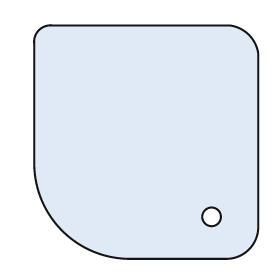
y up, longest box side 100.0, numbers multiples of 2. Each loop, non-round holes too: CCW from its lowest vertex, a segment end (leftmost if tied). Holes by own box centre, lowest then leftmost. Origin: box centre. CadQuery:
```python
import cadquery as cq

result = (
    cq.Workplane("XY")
    .moveTo(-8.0, -50.0)
    .lineTo(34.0, -50.0)
    .threePointArc((44.0, -46.0), (48.0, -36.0))
    .lineTo(48.0, 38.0)
    .threePointArc((44.0, 46.0), (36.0, 50.0))
    .lineTo(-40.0, 50.0)
    .threePointArc((-46.0, 48.0), (-48.0, 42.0))
    .lineTo(-48.0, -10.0)
    .threePointArc((-36.0, -38.0), (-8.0, -50.0))
    .close()
    .moveTo(28.0, -32.0)
    .circle(4.0)
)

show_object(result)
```